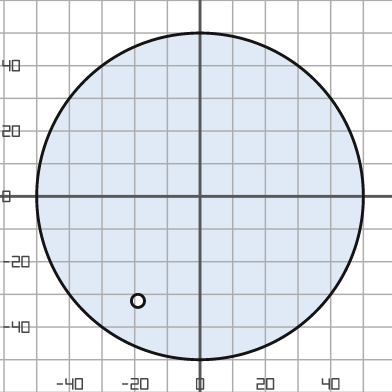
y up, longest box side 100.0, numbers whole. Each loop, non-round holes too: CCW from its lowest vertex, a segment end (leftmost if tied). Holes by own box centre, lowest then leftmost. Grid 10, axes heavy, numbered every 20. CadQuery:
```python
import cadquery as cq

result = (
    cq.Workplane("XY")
    .moveTo(0.0, 0.0)
    .circle(50.0)
    .moveTo(-19.0, -32.0)
    .circle(2.0)
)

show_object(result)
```